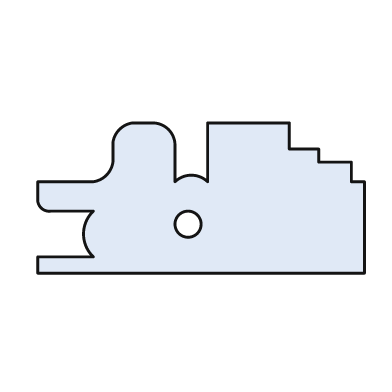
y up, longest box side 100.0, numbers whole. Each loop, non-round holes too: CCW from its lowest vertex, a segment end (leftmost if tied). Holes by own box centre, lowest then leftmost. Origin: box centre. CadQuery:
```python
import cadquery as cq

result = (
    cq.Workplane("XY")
    .moveTo(-50.0, -23.0)
    .lineTo(50.0, -23.0)
    .lineTo(50.0, 5.0)
    .lineTo(46.0, 5.0)
    .lineTo(46.0, 11.0)
    .lineTo(36.0, 11.0)
    .lineTo(36.0, 15.0)
    .lineTo(27.0, 15.0)
    .lineTo(27.0, 23.0)
    .lineTo(2.0, 23.0)
    .lineTo(2.0, 5.0)
    .threePointArc((-3.0, 7.0), (-8.0, 5.0))
    .lineTo(-8.0, 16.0)
    .threePointArc((-10.0, 21.0), (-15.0, 23.0))
    .lineTo(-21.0, 23.0)
    .threePointArc((-25.0, 21.0), (-27.0, 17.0))
    .lineTo(-27.0, 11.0)
    .threePointArc((-29.0, 7.0), (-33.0, 5.0))
    .lineTo(-50.0, 5.0)
    .lineTo(-50.0, 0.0)
    .threePointArc((-49.0, -3.0), (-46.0, -4.0))
    .lineTo(-33.0, -4.0)
    .threePointArc((-36.0, -11.0), (-33.0, -18.0))
    .lineTo(-50.0, -18.0)
    .close()
    .moveTo(-4.0, -8.0)
    .circle(4.0)
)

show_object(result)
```